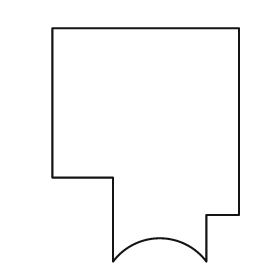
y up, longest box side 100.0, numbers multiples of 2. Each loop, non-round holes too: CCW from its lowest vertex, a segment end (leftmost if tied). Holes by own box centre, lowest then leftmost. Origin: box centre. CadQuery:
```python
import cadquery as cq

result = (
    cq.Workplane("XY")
    .moveTo(-14.0, -50.0)
    .threePointArc((6.0, -40.0), (26.0, -50.0))
    .lineTo(26.0, -30.0)
    .lineTo(40.0, -30.0)
    .lineTo(40.0, 50.0)
    .lineTo(-40.0, 50.0)
    .lineTo(-40.0, -14.0)
    .lineTo(-14.0, -14.0)
    .close()
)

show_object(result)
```